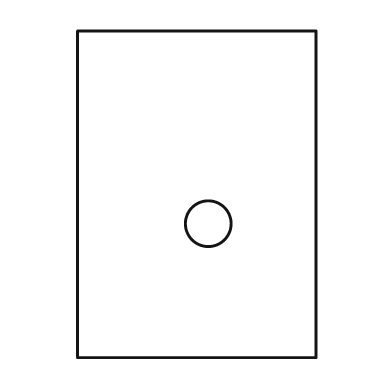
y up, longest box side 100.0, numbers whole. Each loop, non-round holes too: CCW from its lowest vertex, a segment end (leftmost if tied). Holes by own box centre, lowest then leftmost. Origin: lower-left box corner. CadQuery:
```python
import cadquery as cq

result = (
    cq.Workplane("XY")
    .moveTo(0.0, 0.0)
    .lineTo(73.0, 0.0)
    .lineTo(73.0, 100.0)
    .lineTo(0.0, 100.0)
    .close()
    .moveTo(40.0, 41.0)
    .circle(7.0)
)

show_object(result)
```